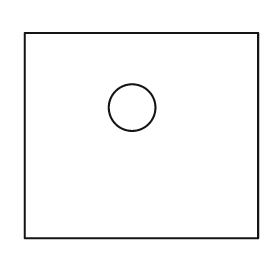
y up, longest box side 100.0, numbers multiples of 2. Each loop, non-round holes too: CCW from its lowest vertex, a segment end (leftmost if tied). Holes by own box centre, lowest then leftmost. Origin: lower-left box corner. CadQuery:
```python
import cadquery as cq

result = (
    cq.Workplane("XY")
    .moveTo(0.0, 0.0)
    .lineTo(100.0, 0.0)
    .lineTo(100.0, 88.0)
    .lineTo(0.0, 88.0)
    .close()
    .moveTo(46.0, 56.0)
    .circle(10.0)
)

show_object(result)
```